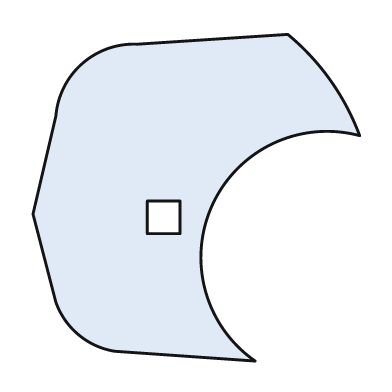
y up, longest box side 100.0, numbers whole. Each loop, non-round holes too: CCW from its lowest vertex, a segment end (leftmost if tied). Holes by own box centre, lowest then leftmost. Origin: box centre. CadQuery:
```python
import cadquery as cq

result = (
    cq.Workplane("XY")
    .moveTo(18.0, -50.0)
    .threePointArc((5.0, -2.0), (50.0, 19.0))
    .threePointArc((41.0, 36.0), (28.0, 50.0))
    .lineTo(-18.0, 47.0)
    .threePointArc((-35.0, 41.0), (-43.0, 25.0))
    .lineTo(-50.0, -5.0)
    .lineTo(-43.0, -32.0)
    .threePointArc((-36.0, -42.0), (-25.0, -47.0))
    .close()
    .moveTo(-15.0, -11.0)
    .lineTo(-5.0, -11.0)
    .lineTo(-5.0, -1.0)
    .lineTo(-15.0, -1.0)
    .close()
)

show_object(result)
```